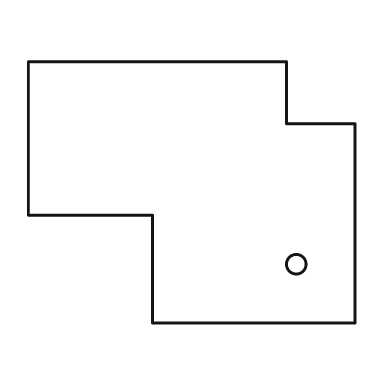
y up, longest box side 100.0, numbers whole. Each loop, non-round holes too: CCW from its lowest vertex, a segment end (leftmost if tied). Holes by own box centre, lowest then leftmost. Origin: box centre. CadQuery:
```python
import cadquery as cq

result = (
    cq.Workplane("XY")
    .moveTo(-12.0, -40.0)
    .lineTo(50.0, -40.0)
    .lineTo(50.0, 21.0)
    .lineTo(29.0, 21.0)
    .lineTo(29.0, 40.0)
    .lineTo(-50.0, 40.0)
    .lineTo(-50.0, -7.0)
    .lineTo(-12.0, -7.0)
    .close()
    .moveTo(32.0, -22.0)
    .circle(3.0)
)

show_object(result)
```